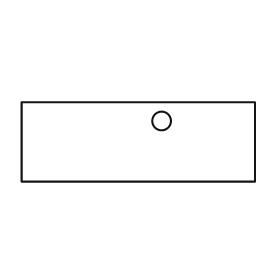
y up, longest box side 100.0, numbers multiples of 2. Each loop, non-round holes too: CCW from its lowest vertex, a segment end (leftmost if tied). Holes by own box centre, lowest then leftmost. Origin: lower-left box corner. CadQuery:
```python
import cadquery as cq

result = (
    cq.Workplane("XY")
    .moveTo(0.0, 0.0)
    .lineTo(100.0, 0.0)
    .lineTo(100.0, 34.0)
    .lineTo(0.0, 34.0)
    .close()
    .moveTo(60.0, 26.0)
    .circle(4.0)
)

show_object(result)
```